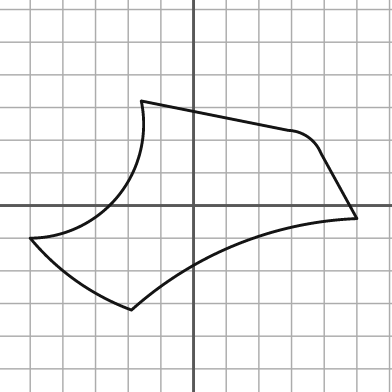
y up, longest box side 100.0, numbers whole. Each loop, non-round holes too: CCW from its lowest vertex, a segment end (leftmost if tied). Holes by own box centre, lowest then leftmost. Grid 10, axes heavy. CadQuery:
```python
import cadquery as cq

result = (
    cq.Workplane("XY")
    .moveTo(-19.0, -32.0)
    .threePointArc((13.0, -12.0), (50.0, -4.0))
    .lineTo(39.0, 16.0)
    .threePointArc((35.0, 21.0), (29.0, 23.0))
    .lineTo(-16.0, 32.0)
    .threePointArc((-23.0, 3.0), (-50.0, -10.0))
    .threePointArc((-36.0, -23.0), (-19.0, -32.0))
    .close()
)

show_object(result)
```